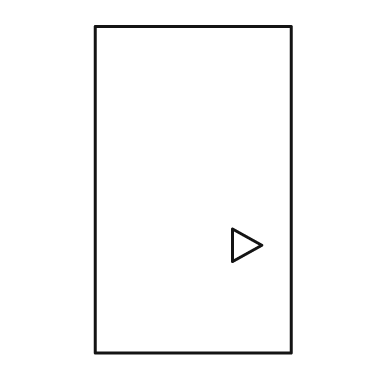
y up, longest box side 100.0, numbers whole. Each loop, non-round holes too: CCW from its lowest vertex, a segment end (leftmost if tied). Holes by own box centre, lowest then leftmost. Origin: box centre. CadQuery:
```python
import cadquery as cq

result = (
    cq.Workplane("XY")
    .moveTo(-30.0, -50.0)
    .lineTo(30.0, -50.0)
    .lineTo(30.0, 50.0)
    .lineTo(-30.0, 50.0)
    .close()
    .moveTo(12.0, -22.0)
    .lineTo(21.0, -17.0)
    .lineTo(12.0, -12.0)
    .close()
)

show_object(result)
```